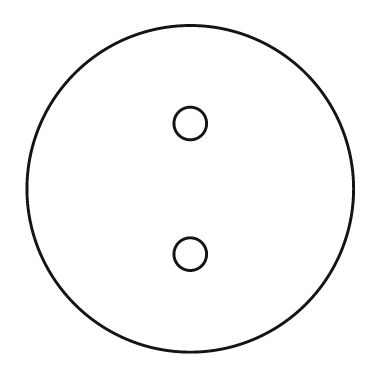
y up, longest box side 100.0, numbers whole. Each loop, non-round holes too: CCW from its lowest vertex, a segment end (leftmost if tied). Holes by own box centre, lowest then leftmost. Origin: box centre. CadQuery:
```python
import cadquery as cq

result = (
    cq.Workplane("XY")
    .moveTo(0.0, 0.0)
    .circle(50.0)
    .moveTo(0.0, -20.0)
    .circle(5.0)
    .moveTo(0.0, 20.0)
    .circle(5.0)
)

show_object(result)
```